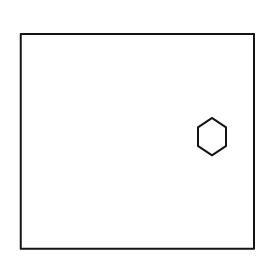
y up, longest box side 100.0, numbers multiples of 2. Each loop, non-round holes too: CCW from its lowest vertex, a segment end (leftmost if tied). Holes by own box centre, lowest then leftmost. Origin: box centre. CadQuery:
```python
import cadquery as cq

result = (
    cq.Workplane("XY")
    .moveTo(-50.0, -46.0)
    .lineTo(50.0, -46.0)
    .lineTo(50.0, 46.0)
    .lineTo(-50.0, 46.0)
    .close()
    .moveTo(32.0, -6.0)
    .lineTo(38.0, -2.0)
    .lineTo(38.0, 6.0)
    .lineTo(32.0, 10.0)
    .lineTo(26.0, 6.0)
    .lineTo(26.0, -2.0)
    .close()
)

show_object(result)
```